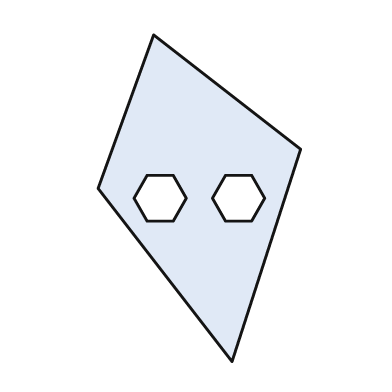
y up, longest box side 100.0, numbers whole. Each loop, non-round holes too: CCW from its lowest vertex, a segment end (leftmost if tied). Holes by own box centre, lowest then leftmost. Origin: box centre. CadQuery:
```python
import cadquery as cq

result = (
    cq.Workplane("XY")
    .moveTo(10.0, -50.0)
    .lineTo(31.0, 15.0)
    .lineTo(-14.0, 50.0)
    .lineTo(-31.0, 3.0)
    .close()
    .moveTo(-16.0, -7.0)
    .lineTo(-8.0, -7.0)
    .lineTo(-4.0, 0.0)
    .lineTo(-8.0, 7.0)
    .lineTo(-16.0, 7.0)
    .lineTo(-20.0, 0.0)
    .close()
    .moveTo(8.0, -7.0)
    .lineTo(16.0, -7.0)
    .lineTo(20.0, 0.0)
    .lineTo(16.0, 7.0)
    .lineTo(8.0, 7.0)
    .lineTo(4.0, 0.0)
    .close()
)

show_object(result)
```